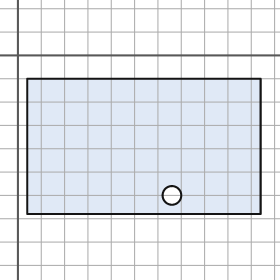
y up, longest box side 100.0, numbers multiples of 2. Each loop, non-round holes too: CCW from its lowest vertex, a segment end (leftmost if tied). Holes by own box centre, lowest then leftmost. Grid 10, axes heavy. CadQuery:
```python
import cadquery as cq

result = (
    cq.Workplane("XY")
    .moveTo(4.0, -68.0)
    .lineTo(104.0, -68.0)
    .lineTo(104.0, -10.0)
    .lineTo(4.0, -10.0)
    .close()
    .moveTo(66.0, -60.0)
    .circle(4.0)
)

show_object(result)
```